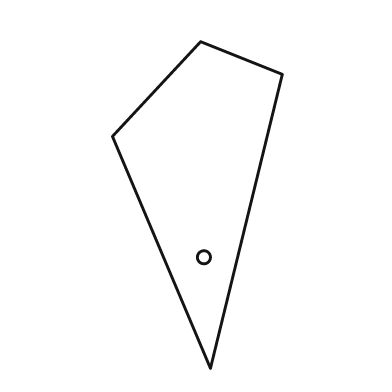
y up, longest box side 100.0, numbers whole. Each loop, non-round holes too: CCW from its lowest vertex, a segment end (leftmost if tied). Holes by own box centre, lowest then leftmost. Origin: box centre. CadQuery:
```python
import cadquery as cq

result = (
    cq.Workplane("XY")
    .moveTo(4.0, -50.0)
    .lineTo(26.0, 40.0)
    .lineTo(1.0, 50.0)
    .lineTo(-26.0, 21.0)
    .close()
    .moveTo(2.0, -16.0)
    .circle(2.0)
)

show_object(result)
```